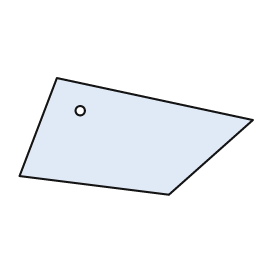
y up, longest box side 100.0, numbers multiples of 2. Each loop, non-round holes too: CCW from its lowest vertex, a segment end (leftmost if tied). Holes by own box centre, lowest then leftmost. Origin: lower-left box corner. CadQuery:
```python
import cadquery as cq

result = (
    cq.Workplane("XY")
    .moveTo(64.0, 0.0)
    .lineTo(100.0, 32.0)
    .lineTo(16.0, 50.0)
    .lineTo(0.0, 8.0)
    .close()
    .moveTo(26.0, 36.0)
    .circle(2.0)
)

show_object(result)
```